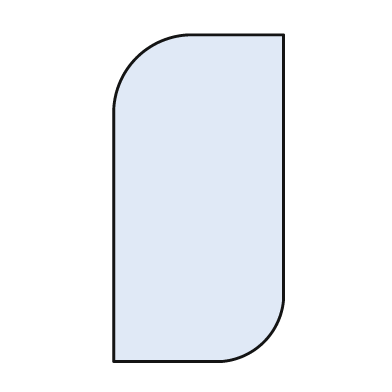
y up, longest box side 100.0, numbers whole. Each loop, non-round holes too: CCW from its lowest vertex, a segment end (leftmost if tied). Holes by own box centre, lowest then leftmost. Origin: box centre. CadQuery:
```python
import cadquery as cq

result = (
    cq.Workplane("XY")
    .moveTo(-26.0, -50.0)
    .lineTo(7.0, -50.0)
    .threePointArc((20.0, -44.0), (26.0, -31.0))
    .lineTo(26.0, 50.0)
    .lineTo(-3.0, 50.0)
    .threePointArc((-19.0, 43.0), (-26.0, 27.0))
    .close()
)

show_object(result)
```